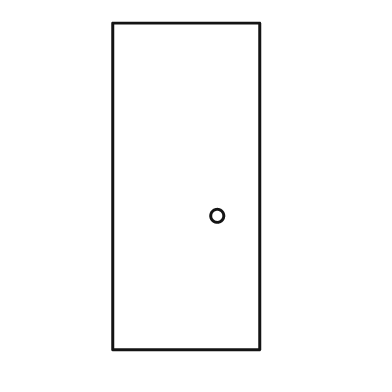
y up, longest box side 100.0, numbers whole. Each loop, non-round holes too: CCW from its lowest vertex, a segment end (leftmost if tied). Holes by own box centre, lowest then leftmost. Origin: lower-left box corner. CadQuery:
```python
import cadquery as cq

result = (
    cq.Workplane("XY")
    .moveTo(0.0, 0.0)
    .lineTo(45.0, 0.0)
    .lineTo(45.0, 100.0)
    .lineTo(0.0, 100.0)
    .close()
    .moveTo(32.0, 41.0)
    .circle(2.0)
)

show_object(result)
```